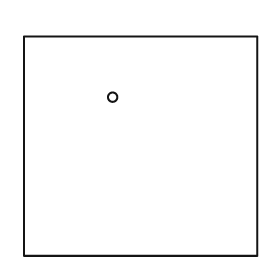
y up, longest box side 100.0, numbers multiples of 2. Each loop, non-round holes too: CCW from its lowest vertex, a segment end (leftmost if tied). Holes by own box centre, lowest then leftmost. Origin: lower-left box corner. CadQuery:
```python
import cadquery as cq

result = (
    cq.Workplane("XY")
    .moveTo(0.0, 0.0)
    .lineTo(100.0, 0.0)
    .lineTo(100.0, 94.0)
    .lineTo(0.0, 94.0)
    .close()
    .moveTo(38.0, 68.0)
    .circle(2.0)
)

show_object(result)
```